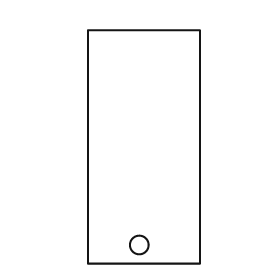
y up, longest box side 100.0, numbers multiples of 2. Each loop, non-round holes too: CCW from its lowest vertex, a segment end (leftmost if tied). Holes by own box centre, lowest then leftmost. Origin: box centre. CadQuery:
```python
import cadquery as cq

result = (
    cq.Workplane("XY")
    .moveTo(-24.0, -50.0)
    .lineTo(24.0, -50.0)
    .lineTo(24.0, 50.0)
    .lineTo(-24.0, 50.0)
    .close()
    .moveTo(-2.0, -42.0)
    .circle(4.0)
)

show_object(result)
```